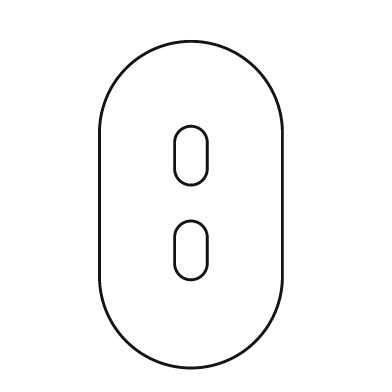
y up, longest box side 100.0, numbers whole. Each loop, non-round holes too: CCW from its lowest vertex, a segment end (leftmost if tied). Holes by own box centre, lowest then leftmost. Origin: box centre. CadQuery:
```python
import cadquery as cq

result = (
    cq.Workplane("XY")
    .moveTo(-28.0, -22.0)
    .threePointArc((0.0, -50.0), (28.0, -22.0))
    .lineTo(28.0, 22.0)
    .threePointArc((0.0, 50.0), (-28.0, 22.0))
    .close()
    .moveTo(-5.0, -18.0)
    .threePointArc((0.0, -23.0), (5.0, -18.0))
    .lineTo(5.0, -10.0)
    .threePointArc((0.0, -5.0), (-5.0, -10.0))
    .close()
    .moveTo(-5.0, 11.0)
    .threePointArc((0.0, 6.0), (5.0, 11.0))
    .lineTo(5.0, 19.0)
    .threePointArc((0.0, 24.0), (-5.0, 19.0))
    .close()
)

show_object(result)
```